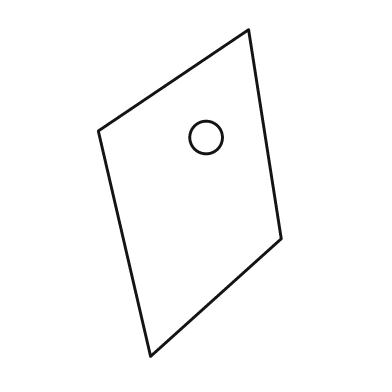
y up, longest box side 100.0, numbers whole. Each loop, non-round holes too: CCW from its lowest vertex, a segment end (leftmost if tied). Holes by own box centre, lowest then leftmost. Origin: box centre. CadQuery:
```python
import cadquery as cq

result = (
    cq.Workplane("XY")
    .moveTo(-12.0, -50.0)
    .lineTo(28.0, -14.0)
    .lineTo(18.0, 50.0)
    .lineTo(-28.0, 19.0)
    .close()
    .moveTo(5.0, 17.0)
    .circle(5.0)
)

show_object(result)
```